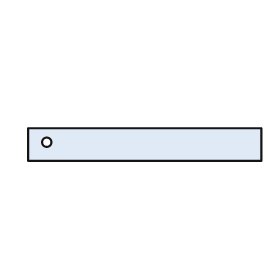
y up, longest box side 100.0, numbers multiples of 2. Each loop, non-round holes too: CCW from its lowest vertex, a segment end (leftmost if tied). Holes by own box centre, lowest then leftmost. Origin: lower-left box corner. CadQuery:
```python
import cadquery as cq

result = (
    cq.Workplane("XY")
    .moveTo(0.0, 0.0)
    .lineTo(100.0, 0.0)
    .lineTo(100.0, 14.0)
    .lineTo(0.0, 14.0)
    .close()
    .moveTo(8.0, 8.0)
    .circle(2.0)
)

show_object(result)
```